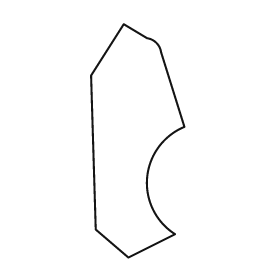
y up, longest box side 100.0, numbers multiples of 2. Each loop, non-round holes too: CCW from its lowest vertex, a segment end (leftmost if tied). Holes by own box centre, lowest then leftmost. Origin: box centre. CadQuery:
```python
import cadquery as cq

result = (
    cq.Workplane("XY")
    .moveTo(-4.0, -50.0)
    .lineTo(16.0, -40.0)
    .threePointArc((4.0, -16.0), (20.0, 6.0))
    .lineTo(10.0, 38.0)
    .threePointArc((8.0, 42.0), (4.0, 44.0))
    .lineTo(-6.0, 50.0)
    .lineTo(-20.0, 28.0)
    .lineTo(-18.0, -38.0)
    .close()
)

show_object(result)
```